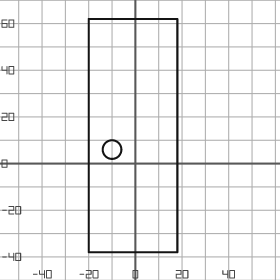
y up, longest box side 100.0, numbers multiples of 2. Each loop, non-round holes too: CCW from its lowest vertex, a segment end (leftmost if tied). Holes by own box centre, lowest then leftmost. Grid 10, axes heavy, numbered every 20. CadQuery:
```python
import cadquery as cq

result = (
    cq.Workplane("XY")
    .moveTo(-20.0, -38.0)
    .lineTo(18.0, -38.0)
    .lineTo(18.0, 62.0)
    .lineTo(-20.0, 62.0)
    .close()
    .moveTo(-10.0, 6.0)
    .circle(4.0)
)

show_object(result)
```